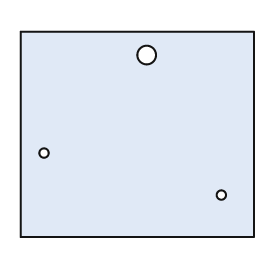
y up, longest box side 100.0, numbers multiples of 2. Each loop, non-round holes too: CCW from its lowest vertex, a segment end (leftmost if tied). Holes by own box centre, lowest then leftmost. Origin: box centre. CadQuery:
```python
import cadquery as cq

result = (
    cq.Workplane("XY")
    .moveTo(-50.0, -44.0)
    .lineTo(50.0, -44.0)
    .lineTo(50.0, 44.0)
    .lineTo(-50.0, 44.0)
    .close()
    .moveTo(36.0, -26.0)
    .circle(2.0)
    .moveTo(-40.0, -8.0)
    .circle(2.0)
    .moveTo(4.0, 34.0)
    .circle(4.0)
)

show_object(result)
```